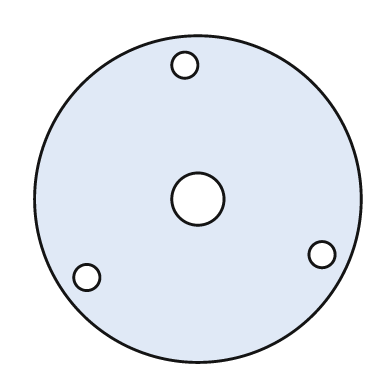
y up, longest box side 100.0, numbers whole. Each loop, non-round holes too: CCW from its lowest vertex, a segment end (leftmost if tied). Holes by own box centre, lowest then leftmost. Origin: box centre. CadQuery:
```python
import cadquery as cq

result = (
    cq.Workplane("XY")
    .moveTo(0.0, 0.0)
    .circle(50.0)
    .moveTo(-34.0, -24.0)
    .circle(4.0)
    .moveTo(38.0, -17.0)
    .circle(4.0)
    .moveTo(0.0, 0.0)
    .circle(8.0)
    .moveTo(-4.0, 41.0)
    .circle(4.0)
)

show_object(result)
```